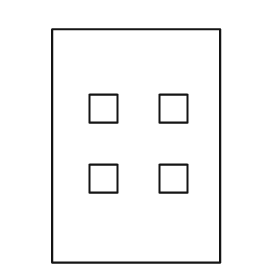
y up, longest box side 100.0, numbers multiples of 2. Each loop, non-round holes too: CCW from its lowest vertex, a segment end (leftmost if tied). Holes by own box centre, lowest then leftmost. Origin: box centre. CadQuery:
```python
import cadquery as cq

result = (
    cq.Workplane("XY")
    .moveTo(-36.0, -50.0)
    .lineTo(36.0, -50.0)
    .lineTo(36.0, 50.0)
    .lineTo(-36.0, 50.0)
    .close()
    .moveTo(-20.0, -20.0)
    .lineTo(-8.0, -20.0)
    .lineTo(-8.0, -8.0)
    .lineTo(-20.0, -8.0)
    .close()
    .moveTo(10.0, -20.0)
    .lineTo(22.0, -20.0)
    .lineTo(22.0, -8.0)
    .lineTo(10.0, -8.0)
    .close()
    .moveTo(-20.0, 10.0)
    .lineTo(-8.0, 10.0)
    .lineTo(-8.0, 22.0)
    .lineTo(-20.0, 22.0)
    .close()
    .moveTo(10.0, 10.0)
    .lineTo(22.0, 10.0)
    .lineTo(22.0, 22.0)
    .lineTo(10.0, 22.0)
    .close()
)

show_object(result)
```